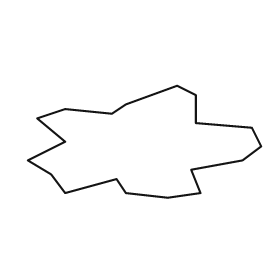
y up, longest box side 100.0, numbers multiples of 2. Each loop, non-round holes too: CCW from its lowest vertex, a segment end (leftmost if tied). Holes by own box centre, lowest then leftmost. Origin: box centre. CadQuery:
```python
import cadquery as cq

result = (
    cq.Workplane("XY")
    .moveTo(10.0, -24.0)
    .lineTo(24.0, -22.0)
    .lineTo(20.0, -12.0)
    .lineTo(42.0, -8.0)
    .lineTo(50.0, -2.0)
    .lineTo(46.0, 6.0)
    .lineTo(22.0, 8.0)
    .lineTo(22.0, 20.0)
    .lineTo(14.0, 24.0)
    .lineTo(-8.0, 16.0)
    .lineTo(-14.0, 12.0)
    .lineTo(-34.0, 14.0)
    .lineTo(-46.0, 10.0)
    .lineTo(-34.0, 0.0)
    .lineTo(-50.0, -8.0)
    .lineTo(-40.0, -14.0)
    .lineTo(-34.0, -22.0)
    .lineTo(-12.0, -16.0)
    .lineTo(-8.0, -22.0)
    .close()
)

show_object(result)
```